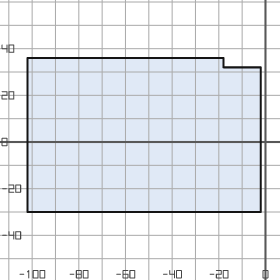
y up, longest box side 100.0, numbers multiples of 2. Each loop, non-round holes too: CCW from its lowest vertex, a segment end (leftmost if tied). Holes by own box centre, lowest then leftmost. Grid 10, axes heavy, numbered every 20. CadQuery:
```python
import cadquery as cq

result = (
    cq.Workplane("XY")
    .moveTo(-102.0, -30.0)
    .lineTo(-2.0, -30.0)
    .lineTo(-2.0, 32.0)
    .lineTo(-18.0, 32.0)
    .lineTo(-18.0, 36.0)
    .lineTo(-102.0, 36.0)
    .close()
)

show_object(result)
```